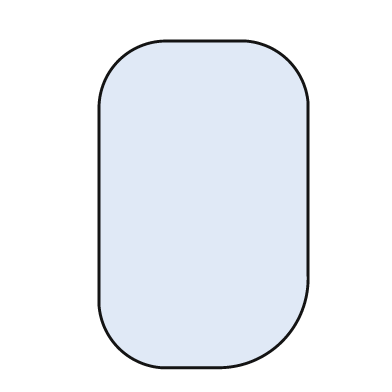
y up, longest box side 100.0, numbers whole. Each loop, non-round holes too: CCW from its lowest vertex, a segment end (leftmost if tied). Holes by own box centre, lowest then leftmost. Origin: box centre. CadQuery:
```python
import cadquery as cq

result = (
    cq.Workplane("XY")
    .moveTo(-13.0, -50.0)
    .lineTo(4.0, -50.0)
    .threePointArc((24.0, -42.0), (32.0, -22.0))
    .lineTo(32.0, 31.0)
    .threePointArc((26.0, 44.0), (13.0, 50.0))
    .lineTo(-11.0, 50.0)
    .threePointArc((-26.0, 44.0), (-32.0, 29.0))
    .lineTo(-32.0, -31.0)
    .threePointArc((-26.0, -44.0), (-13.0, -50.0))
    .close()
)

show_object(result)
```